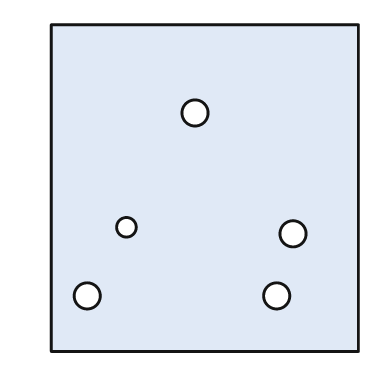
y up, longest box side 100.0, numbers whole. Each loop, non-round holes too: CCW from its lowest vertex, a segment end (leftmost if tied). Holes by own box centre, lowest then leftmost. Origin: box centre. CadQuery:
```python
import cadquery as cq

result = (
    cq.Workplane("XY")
    .moveTo(-47.0, -50.0)
    .lineTo(47.0, -50.0)
    .lineTo(47.0, 50.0)
    .lineTo(-47.0, 50.0)
    .close()
    .moveTo(-36.0, -33.0)
    .circle(4.0)
    .moveTo(22.0, -33.0)
    .circle(4.0)
    .moveTo(27.0, -14.0)
    .circle(4.0)
    .moveTo(-24.0, -12.0)
    .circle(3.0)
    .moveTo(-3.0, 23.0)
    .circle(4.0)
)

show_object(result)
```